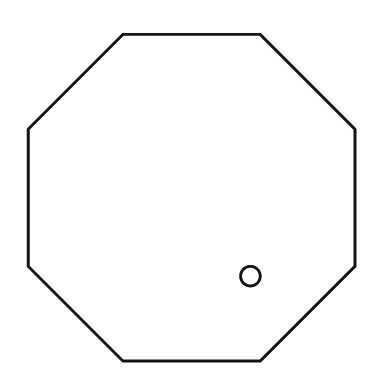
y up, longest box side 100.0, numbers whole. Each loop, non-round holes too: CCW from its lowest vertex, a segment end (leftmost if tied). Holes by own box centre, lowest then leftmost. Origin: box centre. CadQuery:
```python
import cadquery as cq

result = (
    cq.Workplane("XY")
    .moveTo(-21.0, -50.0)
    .lineTo(21.0, -50.0)
    .lineTo(50.0, -21.0)
    .lineTo(50.0, 21.0)
    .lineTo(21.0, 50.0)
    .lineTo(-21.0, 50.0)
    .lineTo(-50.0, 21.0)
    .lineTo(-50.0, -21.0)
    .close()
    .moveTo(18.0, -24.0)
    .circle(3.0)
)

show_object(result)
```